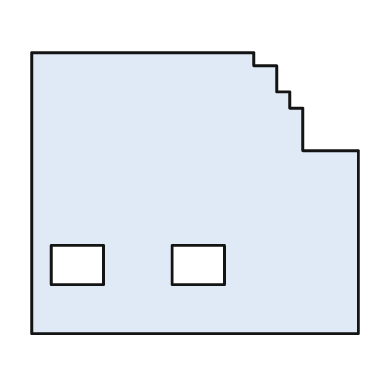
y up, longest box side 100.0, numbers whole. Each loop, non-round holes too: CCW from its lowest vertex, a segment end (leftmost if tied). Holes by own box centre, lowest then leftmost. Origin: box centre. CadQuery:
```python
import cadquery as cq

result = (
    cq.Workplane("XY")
    .moveTo(-50.0, -43.0)
    .lineTo(50.0, -43.0)
    .lineTo(50.0, 13.0)
    .lineTo(33.0, 13.0)
    .lineTo(33.0, 26.0)
    .lineTo(29.0, 26.0)
    .lineTo(29.0, 31.0)
    .lineTo(25.0, 31.0)
    .lineTo(25.0, 39.0)
    .lineTo(18.0, 39.0)
    .lineTo(18.0, 43.0)
    .lineTo(-50.0, 43.0)
    .close()
    .moveTo(-44.0, -28.0)
    .lineTo(-28.0, -28.0)
    .lineTo(-28.0, -16.0)
    .lineTo(-44.0, -16.0)
    .close()
    .moveTo(-7.0, -28.0)
    .lineTo(9.0, -28.0)
    .lineTo(9.0, -16.0)
    .lineTo(-7.0, -16.0)
    .close()
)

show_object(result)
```